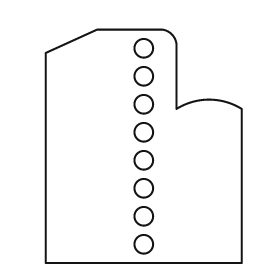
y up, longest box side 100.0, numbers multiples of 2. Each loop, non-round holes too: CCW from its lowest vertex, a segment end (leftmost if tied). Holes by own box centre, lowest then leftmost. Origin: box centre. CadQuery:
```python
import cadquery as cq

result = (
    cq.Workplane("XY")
    .moveTo(-42.0, -50.0)
    .lineTo(42.0, -50.0)
    .lineTo(42.0, 16.0)
    .threePointArc((28.0, 20.0), (14.0, 16.0))
    .lineTo(14.0, 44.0)
    .threePointArc((12.0, 48.0), (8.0, 50.0))
    .lineTo(-20.0, 50.0)
    .lineTo(-42.0, 40.0)
    .close()
    .moveTo(0.0, -42.0)
    .circle(4.0)
    .moveTo(0.0, -30.0)
    .circle(4.0)
    .moveTo(0.0, -18.0)
    .circle(4.0)
    .moveTo(0.0, -6.0)
    .circle(4.0)
    .moveTo(0.0, 6.0)
    .circle(4.0)
    .moveTo(0.0, 18.0)
    .circle(4.0)
    .moveTo(0.0, 30.0)
    .circle(4.0)
    .moveTo(0.0, 42.0)
    .circle(4.0)
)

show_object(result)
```